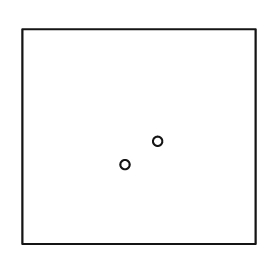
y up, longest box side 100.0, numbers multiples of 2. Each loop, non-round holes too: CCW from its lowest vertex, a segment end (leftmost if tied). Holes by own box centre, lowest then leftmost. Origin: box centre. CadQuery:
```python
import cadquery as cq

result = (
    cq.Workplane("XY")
    .moveTo(-50.0, -46.0)
    .lineTo(50.0, -46.0)
    .lineTo(50.0, 46.0)
    .lineTo(-50.0, 46.0)
    .close()
    .moveTo(-6.0, -12.0)
    .circle(2.0)
    .moveTo(8.0, -2.0)
    .circle(2.0)
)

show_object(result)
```